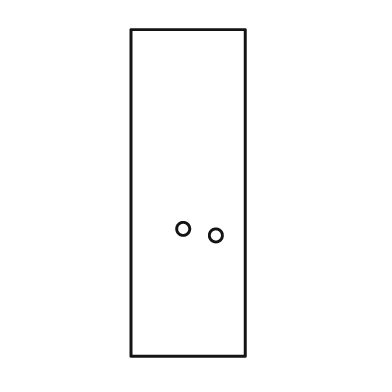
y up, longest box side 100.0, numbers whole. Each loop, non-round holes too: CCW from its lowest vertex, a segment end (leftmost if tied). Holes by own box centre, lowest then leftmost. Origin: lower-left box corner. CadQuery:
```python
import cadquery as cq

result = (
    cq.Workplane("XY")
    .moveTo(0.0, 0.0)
    .lineTo(35.0, 0.0)
    .lineTo(35.0, 100.0)
    .lineTo(0.0, 100.0)
    .close()
    .moveTo(26.0, 37.0)
    .circle(2.0)
    .moveTo(16.0, 39.0)
    .circle(2.0)
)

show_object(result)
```